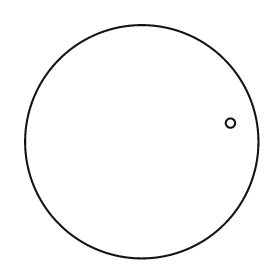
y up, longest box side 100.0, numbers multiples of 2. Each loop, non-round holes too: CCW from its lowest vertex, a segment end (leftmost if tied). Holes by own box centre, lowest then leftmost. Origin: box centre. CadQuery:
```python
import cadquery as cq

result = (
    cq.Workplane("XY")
    .moveTo(0.0, 0.0)
    .circle(50.0)
    .moveTo(38.0, 8.0)
    .circle(2.0)
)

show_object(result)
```